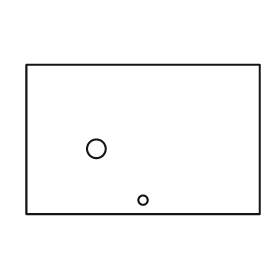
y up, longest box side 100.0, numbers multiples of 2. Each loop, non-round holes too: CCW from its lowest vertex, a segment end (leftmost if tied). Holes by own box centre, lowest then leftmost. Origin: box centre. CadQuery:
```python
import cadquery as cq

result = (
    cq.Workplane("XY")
    .moveTo(-50.0, -32.0)
    .lineTo(50.0, -32.0)
    .lineTo(50.0, 32.0)
    .lineTo(-50.0, 32.0)
    .close()
    .moveTo(0.0, -26.0)
    .circle(2.0)
    .moveTo(-20.0, -4.0)
    .circle(4.0)
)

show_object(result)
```